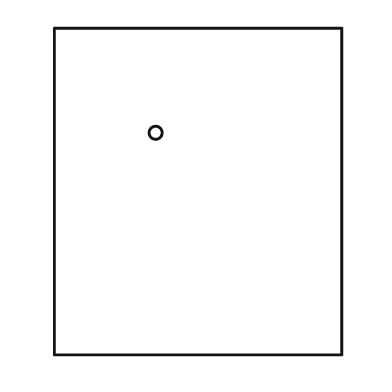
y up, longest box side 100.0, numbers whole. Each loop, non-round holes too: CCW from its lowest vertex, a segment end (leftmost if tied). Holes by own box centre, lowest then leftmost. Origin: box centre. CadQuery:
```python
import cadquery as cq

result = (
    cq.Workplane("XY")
    .moveTo(-44.0, -50.0)
    .lineTo(44.0, -50.0)
    .lineTo(44.0, 50.0)
    .lineTo(-44.0, 50.0)
    .close()
    .moveTo(-13.0, 18.0)
    .circle(2.0)
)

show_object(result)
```